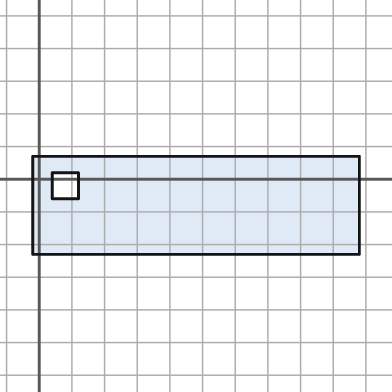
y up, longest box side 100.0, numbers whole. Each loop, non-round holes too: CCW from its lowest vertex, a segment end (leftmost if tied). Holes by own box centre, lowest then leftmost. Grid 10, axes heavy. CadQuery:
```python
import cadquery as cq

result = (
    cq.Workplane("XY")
    .moveTo(-2.0, -23.0)
    .lineTo(98.0, -23.0)
    .lineTo(98.0, 7.0)
    .lineTo(-2.0, 7.0)
    .close()
    .moveTo(4.0, -6.0)
    .lineTo(12.0, -6.0)
    .lineTo(12.0, 2.0)
    .lineTo(4.0, 2.0)
    .close()
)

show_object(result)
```